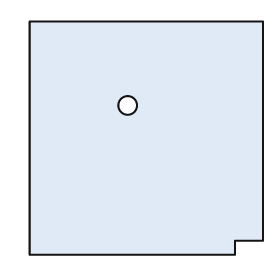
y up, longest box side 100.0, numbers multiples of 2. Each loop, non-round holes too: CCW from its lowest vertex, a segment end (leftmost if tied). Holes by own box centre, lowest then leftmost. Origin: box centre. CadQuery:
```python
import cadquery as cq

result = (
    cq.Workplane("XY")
    .moveTo(-50.0, -50.0)
    .lineTo(38.0, -50.0)
    .lineTo(38.0, -44.0)
    .lineTo(50.0, -44.0)
    .lineTo(50.0, 50.0)
    .lineTo(-50.0, 50.0)
    .close()
    .moveTo(-8.0, 14.0)
    .circle(4.0)
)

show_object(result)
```